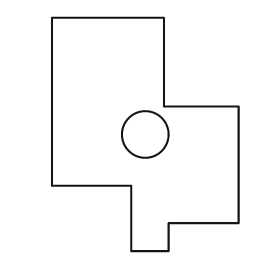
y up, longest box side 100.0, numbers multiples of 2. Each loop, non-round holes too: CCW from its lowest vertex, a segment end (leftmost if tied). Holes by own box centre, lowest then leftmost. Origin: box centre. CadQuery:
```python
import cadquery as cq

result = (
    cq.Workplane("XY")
    .moveTo(-6.0, -50.0)
    .lineTo(10.0, -50.0)
    .lineTo(10.0, -38.0)
    .lineTo(40.0, -38.0)
    .lineTo(40.0, 12.0)
    .lineTo(8.0, 12.0)
    .lineTo(8.0, 50.0)
    .lineTo(-40.0, 50.0)
    .lineTo(-40.0, -22.0)
    .lineTo(-6.0, -22.0)
    .close()
    .moveTo(0.0, 0.0)
    .circle(10.0)
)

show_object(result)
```